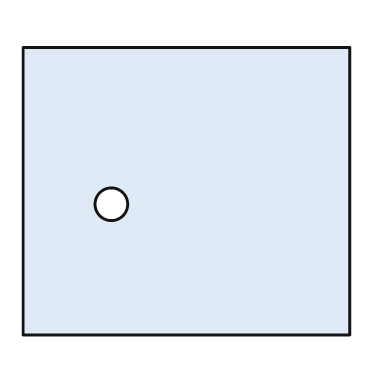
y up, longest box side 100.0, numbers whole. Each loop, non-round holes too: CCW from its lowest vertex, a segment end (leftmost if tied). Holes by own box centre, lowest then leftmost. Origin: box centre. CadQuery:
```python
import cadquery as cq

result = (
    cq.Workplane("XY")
    .moveTo(-50.0, -44.0)
    .lineTo(50.0, -44.0)
    .lineTo(50.0, 44.0)
    .lineTo(-50.0, 44.0)
    .close()
    .moveTo(-23.0, -4.0)
    .circle(5.0)
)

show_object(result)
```